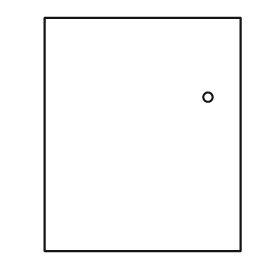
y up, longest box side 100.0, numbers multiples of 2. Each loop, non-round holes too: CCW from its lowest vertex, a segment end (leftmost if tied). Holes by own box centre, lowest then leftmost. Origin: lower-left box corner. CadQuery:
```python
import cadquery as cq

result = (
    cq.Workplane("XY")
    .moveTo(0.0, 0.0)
    .lineTo(84.0, 0.0)
    .lineTo(84.0, 100.0)
    .lineTo(0.0, 100.0)
    .close()
    .moveTo(70.0, 66.0)
    .circle(2.0)
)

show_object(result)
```